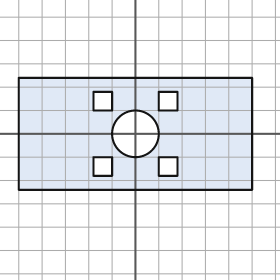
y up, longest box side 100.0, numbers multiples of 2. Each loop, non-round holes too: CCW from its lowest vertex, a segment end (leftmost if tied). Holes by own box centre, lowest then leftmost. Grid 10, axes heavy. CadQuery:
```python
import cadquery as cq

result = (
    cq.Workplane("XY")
    .moveTo(-50.0, -24.0)
    .lineTo(50.0, -24.0)
    .lineTo(50.0, 24.0)
    .lineTo(-50.0, 24.0)
    .close()
    .moveTo(-18.0, -18.0)
    .lineTo(-10.0, -18.0)
    .lineTo(-10.0, -10.0)
    .lineTo(-18.0, -10.0)
    .close()
    .moveTo(10.0, -18.0)
    .lineTo(18.0, -18.0)
    .lineTo(18.0, -10.0)
    .lineTo(10.0, -10.0)
    .close()
    .moveTo(0.0, 0.0)
    .circle(10.0)
    .moveTo(-18.0, 10.0)
    .lineTo(-10.0, 10.0)
    .lineTo(-10.0, 18.0)
    .lineTo(-18.0, 18.0)
    .close()
    .moveTo(10.0, 10.0)
    .lineTo(18.0, 10.0)
    .lineTo(18.0, 18.0)
    .lineTo(10.0, 18.0)
    .close()
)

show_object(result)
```